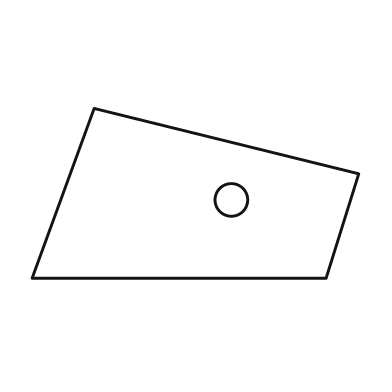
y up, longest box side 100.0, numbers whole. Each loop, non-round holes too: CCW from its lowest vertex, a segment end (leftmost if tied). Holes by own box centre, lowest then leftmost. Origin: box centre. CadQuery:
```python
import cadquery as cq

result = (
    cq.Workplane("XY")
    .moveTo(-50.0, -26.0)
    .lineTo(40.0, -26.0)
    .lineTo(50.0, 6.0)
    .lineTo(-31.0, 26.0)
    .close()
    .moveTo(11.0, -2.0)
    .circle(5.0)
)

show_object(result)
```